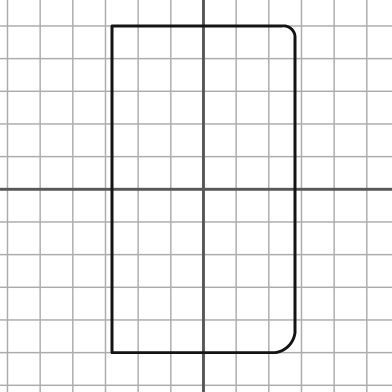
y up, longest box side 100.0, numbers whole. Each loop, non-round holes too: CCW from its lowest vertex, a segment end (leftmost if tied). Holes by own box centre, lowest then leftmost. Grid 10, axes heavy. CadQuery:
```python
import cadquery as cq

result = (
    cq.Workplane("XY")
    .moveTo(-28.0, -50.0)
    .lineTo(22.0, -50.0)
    .threePointArc((26.0, -48.0), (28.0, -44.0))
    .lineTo(28.0, 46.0)
    .threePointArc((27.0, 49.0), (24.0, 50.0))
    .lineTo(-28.0, 50.0)
    .close()
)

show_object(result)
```